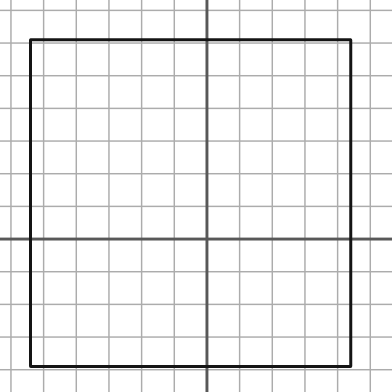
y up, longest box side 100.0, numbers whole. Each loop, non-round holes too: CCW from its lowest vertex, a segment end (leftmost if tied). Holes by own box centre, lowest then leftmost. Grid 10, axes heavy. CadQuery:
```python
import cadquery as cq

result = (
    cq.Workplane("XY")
    .moveTo(-54.0, -39.0)
    .lineTo(44.0, -39.0)
    .lineTo(44.0, 61.0)
    .lineTo(-54.0, 61.0)
    .close()
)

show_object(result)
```